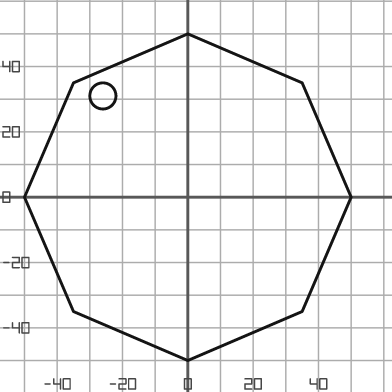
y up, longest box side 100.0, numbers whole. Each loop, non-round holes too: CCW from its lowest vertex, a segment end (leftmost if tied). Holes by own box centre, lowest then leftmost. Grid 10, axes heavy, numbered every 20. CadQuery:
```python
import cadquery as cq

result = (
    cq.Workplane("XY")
    .moveTo(0.0, -50.0)
    .lineTo(35.0, -35.0)
    .lineTo(50.0, 0.0)
    .lineTo(35.0, 35.0)
    .lineTo(0.0, 50.0)
    .lineTo(-35.0, 35.0)
    .lineTo(-50.0, 0.0)
    .lineTo(-35.0, -35.0)
    .close()
    .moveTo(-26.0, 31.0)
    .circle(4.0)
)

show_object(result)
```